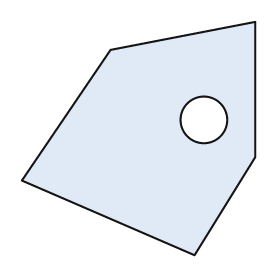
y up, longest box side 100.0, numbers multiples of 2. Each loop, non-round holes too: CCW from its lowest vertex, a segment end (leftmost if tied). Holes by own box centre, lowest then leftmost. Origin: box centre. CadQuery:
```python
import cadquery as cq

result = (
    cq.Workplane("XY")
    .moveTo(24.0, -50.0)
    .lineTo(50.0, -8.0)
    .lineTo(50.0, 50.0)
    .lineTo(-12.0, 38.0)
    .lineTo(-50.0, -18.0)
    .close()
    .moveTo(28.0, 8.0)
    .circle(10.0)
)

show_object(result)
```